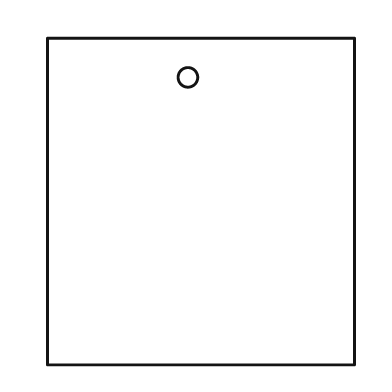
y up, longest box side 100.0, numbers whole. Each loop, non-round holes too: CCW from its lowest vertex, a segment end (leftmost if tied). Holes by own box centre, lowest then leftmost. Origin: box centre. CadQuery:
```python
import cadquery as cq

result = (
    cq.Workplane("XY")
    .moveTo(-47.0, -50.0)
    .lineTo(47.0, -50.0)
    .lineTo(47.0, 50.0)
    .lineTo(-47.0, 50.0)
    .close()
    .moveTo(-4.0, 38.0)
    .circle(3.0)
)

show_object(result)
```